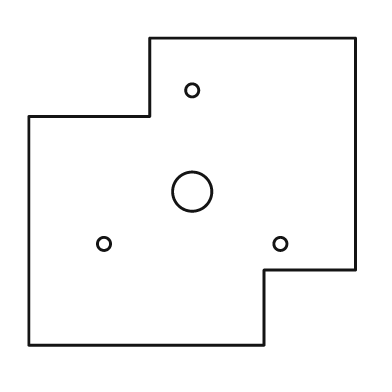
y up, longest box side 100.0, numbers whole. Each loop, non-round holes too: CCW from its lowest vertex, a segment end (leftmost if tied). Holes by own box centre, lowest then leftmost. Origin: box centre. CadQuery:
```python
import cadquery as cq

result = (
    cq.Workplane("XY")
    .moveTo(-50.0, -47.0)
    .lineTo(22.0, -47.0)
    .lineTo(22.0, -24.0)
    .lineTo(50.0, -24.0)
    .lineTo(50.0, 47.0)
    .lineTo(-13.0, 47.0)
    .lineTo(-13.0, 23.0)
    .lineTo(-50.0, 23.0)
    .close()
    .moveTo(-27.0, -16.0)
    .circle(2.0)
    .moveTo(27.0, -16.0)
    .circle(2.0)
    .moveTo(0.0, 0.0)
    .circle(6.0)
    .moveTo(0.0, 31.0)
    .circle(2.0)
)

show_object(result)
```